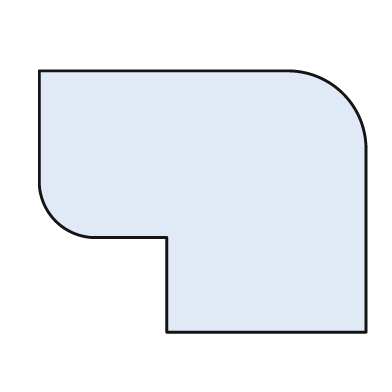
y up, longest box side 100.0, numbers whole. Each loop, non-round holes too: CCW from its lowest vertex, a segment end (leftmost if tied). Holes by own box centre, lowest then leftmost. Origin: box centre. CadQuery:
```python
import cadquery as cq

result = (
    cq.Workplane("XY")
    .moveTo(-11.0, -40.0)
    .lineTo(50.0, -40.0)
    .lineTo(50.0, 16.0)
    .threePointArc((43.0, 33.0), (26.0, 40.0))
    .lineTo(-50.0, 40.0)
    .lineTo(-50.0, 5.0)
    .threePointArc((-45.0, -6.0), (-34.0, -11.0))
    .lineTo(-11.0, -11.0)
    .close()
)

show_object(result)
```